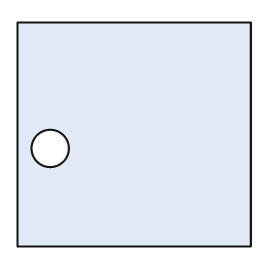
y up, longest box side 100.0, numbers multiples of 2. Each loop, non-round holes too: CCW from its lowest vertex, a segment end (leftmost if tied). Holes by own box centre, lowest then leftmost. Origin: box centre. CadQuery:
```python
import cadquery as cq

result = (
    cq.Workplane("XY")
    .moveTo(-50.0, -48.0)
    .lineTo(50.0, -48.0)
    .lineTo(50.0, 48.0)
    .lineTo(-50.0, 48.0)
    .close()
    .moveTo(-36.0, -6.0)
    .circle(8.0)
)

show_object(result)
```